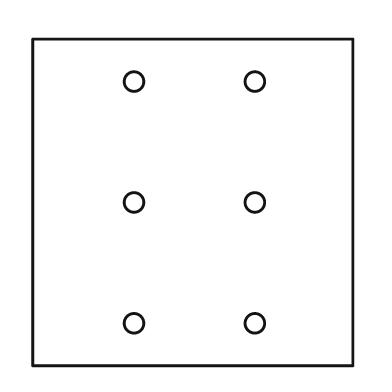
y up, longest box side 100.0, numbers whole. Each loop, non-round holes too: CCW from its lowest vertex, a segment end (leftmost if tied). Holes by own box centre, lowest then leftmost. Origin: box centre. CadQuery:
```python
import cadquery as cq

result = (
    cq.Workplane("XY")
    .moveTo(-49.0, -50.0)
    .lineTo(49.0, -50.0)
    .lineTo(49.0, 50.0)
    .lineTo(-49.0, 50.0)
    .close()
    .moveTo(-18.0, -37.0)
    .circle(3.0)
    .moveTo(19.0, -37.0)
    .circle(3.0)
    .moveTo(-18.0, 0.0)
    .circle(3.0)
    .moveTo(19.0, 0.0)
    .circle(3.0)
    .moveTo(-18.0, 37.0)
    .circle(3.0)
    .moveTo(19.0, 37.0)
    .circle(3.0)
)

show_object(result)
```